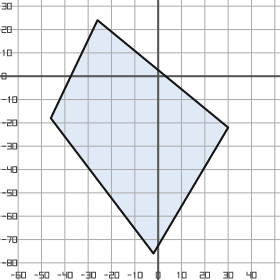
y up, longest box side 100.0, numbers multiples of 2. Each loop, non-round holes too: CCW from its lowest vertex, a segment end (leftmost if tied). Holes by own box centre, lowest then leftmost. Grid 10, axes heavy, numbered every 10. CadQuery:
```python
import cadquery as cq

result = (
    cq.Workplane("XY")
    .moveTo(-2.0, -76.0)
    .lineTo(30.0, -22.0)
    .lineTo(-26.0, 24.0)
    .lineTo(-46.0, -18.0)
    .close()
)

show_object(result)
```